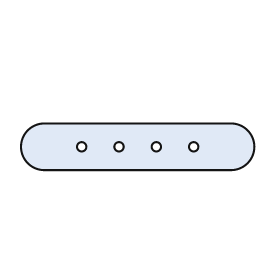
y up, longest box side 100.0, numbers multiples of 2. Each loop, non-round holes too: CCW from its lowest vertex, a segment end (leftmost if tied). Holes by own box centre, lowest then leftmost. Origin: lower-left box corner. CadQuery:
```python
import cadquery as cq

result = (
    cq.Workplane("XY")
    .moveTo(10.0, 0.0)
    .lineTo(90.0, 0.0)
    .threePointArc((100.0, 10.0), (90.0, 20.0))
    .lineTo(10.0, 20.0)
    .threePointArc((0.0, 10.0), (10.0, 0.0))
    .close()
    .moveTo(26.0, 10.0)
    .circle(2.0)
    .moveTo(42.0, 10.0)
    .circle(2.0)
    .moveTo(58.0, 10.0)
    .circle(2.0)
    .moveTo(74.0, 10.0)
    .circle(2.0)
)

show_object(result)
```